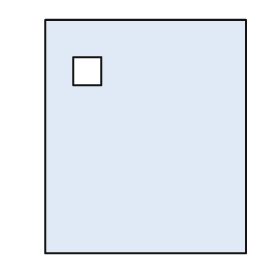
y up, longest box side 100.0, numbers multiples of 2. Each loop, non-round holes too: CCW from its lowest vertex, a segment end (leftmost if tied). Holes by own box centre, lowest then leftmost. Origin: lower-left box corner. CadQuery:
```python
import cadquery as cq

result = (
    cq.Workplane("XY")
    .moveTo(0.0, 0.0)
    .lineTo(86.0, 0.0)
    .lineTo(86.0, 100.0)
    .lineTo(0.0, 100.0)
    .close()
    .moveTo(12.0, 72.0)
    .lineTo(24.0, 72.0)
    .lineTo(24.0, 84.0)
    .lineTo(12.0, 84.0)
    .close()
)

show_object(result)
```